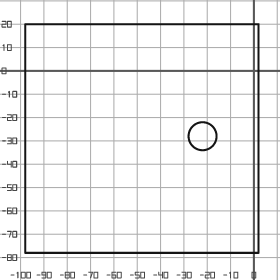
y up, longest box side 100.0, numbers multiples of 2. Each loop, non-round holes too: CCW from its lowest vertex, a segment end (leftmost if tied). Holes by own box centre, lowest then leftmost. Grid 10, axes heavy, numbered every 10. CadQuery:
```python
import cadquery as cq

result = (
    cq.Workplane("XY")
    .moveTo(-98.0, -78.0)
    .lineTo(2.0, -78.0)
    .lineTo(2.0, 20.0)
    .lineTo(-98.0, 20.0)
    .close()
    .moveTo(-22.0, -28.0)
    .circle(6.0)
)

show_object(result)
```